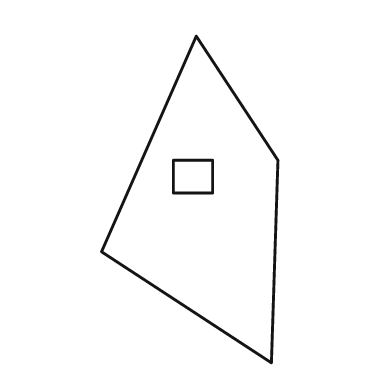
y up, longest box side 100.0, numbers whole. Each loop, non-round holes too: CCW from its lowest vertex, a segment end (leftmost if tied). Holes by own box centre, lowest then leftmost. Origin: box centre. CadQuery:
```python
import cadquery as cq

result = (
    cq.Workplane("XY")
    .moveTo(25.0, -50.0)
    .lineTo(27.0, 12.0)
    .lineTo(2.0, 50.0)
    .lineTo(-27.0, -16.0)
    .close()
    .moveTo(-5.0, 2.0)
    .lineTo(7.0, 2.0)
    .lineTo(7.0, 12.0)
    .lineTo(-5.0, 12.0)
    .close()
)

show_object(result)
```